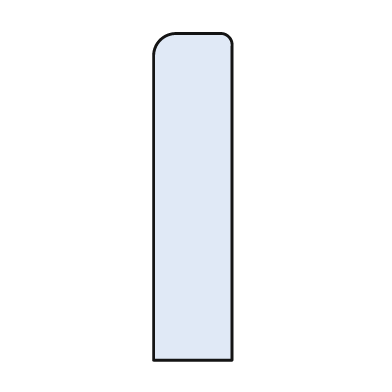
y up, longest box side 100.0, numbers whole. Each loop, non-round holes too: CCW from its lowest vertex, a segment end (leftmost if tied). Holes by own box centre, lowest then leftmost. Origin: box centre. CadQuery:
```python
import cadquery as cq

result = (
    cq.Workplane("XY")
    .moveTo(-12.0, -50.0)
    .lineTo(12.0, -50.0)
    .lineTo(12.0, 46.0)
    .threePointArc((11.0, 49.0), (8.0, 50.0))
    .lineTo(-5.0, 50.0)
    .threePointArc((-10.0, 48.0), (-12.0, 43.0))
    .close()
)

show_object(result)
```